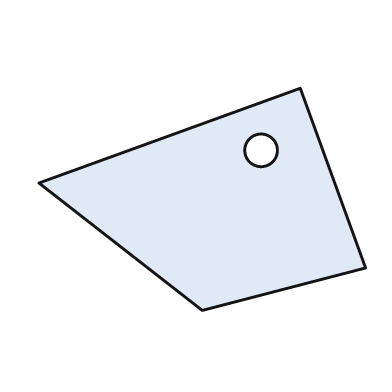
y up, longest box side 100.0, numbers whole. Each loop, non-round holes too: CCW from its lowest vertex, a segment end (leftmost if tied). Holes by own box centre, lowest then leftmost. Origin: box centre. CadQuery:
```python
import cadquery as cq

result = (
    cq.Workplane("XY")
    .moveTo(0.0, -34.0)
    .lineTo(50.0, -21.0)
    .lineTo(30.0, 34.0)
    .lineTo(-50.0, 5.0)
    .close()
    .moveTo(18.0, 15.0)
    .circle(5.0)
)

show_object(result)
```